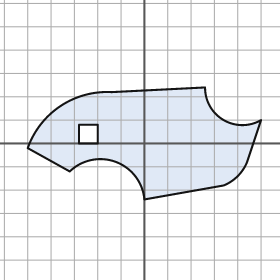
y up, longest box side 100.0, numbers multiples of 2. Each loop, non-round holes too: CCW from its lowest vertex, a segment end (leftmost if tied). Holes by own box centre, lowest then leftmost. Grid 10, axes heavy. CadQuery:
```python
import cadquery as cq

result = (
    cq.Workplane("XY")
    .moveTo(0.0, -24.0)
    .lineTo(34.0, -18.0)
    .threePointArc((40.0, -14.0), (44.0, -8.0))
    .lineTo(50.0, 10.0)
    .threePointArc((34.0, 10.0), (26.0, 24.0))
    .lineTo(-14.0, 22.0)
    .threePointArc((-36.0, 16.0), (-50.0, -2.0))
    .lineTo(-32.0, -12.0)
    .threePointArc((-12.0, -8.0), (0.0, -24.0))
    .close()
    .moveTo(-28.0, 0.0)
    .lineTo(-20.0, 0.0)
    .lineTo(-20.0, 8.0)
    .lineTo(-28.0, 8.0)
    .close()
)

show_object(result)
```